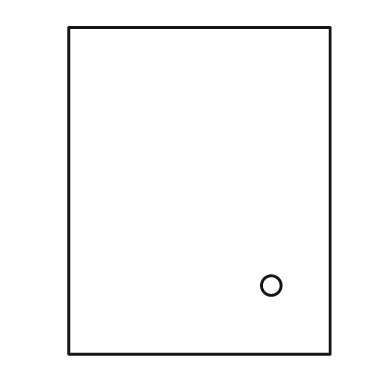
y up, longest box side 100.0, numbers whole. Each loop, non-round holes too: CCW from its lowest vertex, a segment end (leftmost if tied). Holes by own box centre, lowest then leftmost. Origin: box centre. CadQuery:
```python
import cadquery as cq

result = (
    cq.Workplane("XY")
    .moveTo(-40.0, -50.0)
    .lineTo(40.0, -50.0)
    .lineTo(40.0, 50.0)
    .lineTo(-40.0, 50.0)
    .close()
    .moveTo(22.0, -29.0)
    .circle(3.0)
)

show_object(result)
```